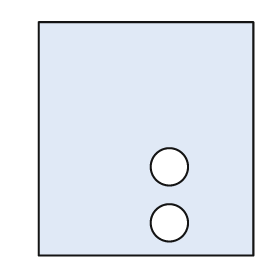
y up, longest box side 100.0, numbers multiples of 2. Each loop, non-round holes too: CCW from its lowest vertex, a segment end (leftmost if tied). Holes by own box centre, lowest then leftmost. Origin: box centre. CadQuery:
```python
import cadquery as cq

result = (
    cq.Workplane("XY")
    .moveTo(-46.0, -50.0)
    .lineTo(46.0, -50.0)
    .lineTo(46.0, 50.0)
    .lineTo(-46.0, 50.0)
    .close()
    .moveTo(10.0, -36.0)
    .circle(8.0)
    .moveTo(10.0, -12.0)
    .circle(8.0)
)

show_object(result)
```